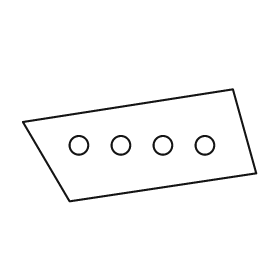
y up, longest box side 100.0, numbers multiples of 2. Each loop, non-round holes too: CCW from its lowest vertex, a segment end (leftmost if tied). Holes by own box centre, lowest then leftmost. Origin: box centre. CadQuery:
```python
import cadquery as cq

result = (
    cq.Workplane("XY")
    .moveTo(-30.0, -24.0)
    .lineTo(50.0, -12.0)
    .lineTo(40.0, 24.0)
    .lineTo(-50.0, 10.0)
    .close()
    .moveTo(-26.0, 0.0)
    .circle(4.0)
    .moveTo(-8.0, 0.0)
    .circle(4.0)
    .moveTo(10.0, 0.0)
    .circle(4.0)
    .moveTo(28.0, 0.0)
    .circle(4.0)
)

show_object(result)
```